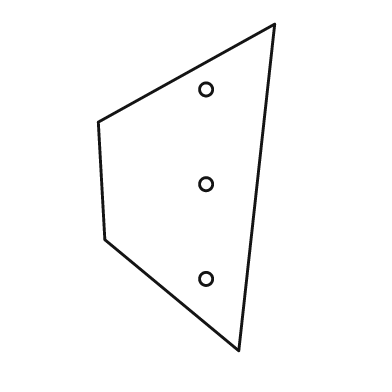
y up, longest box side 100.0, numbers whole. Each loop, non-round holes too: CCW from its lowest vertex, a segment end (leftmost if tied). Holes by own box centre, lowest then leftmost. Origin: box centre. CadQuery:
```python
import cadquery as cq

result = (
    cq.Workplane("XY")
    .moveTo(16.0, -50.0)
    .lineTo(27.0, 50.0)
    .lineTo(-27.0, 20.0)
    .lineTo(-25.0, -16.0)
    .close()
    .moveTo(6.0, -28.0)
    .circle(2.0)
    .moveTo(6.0, 1.0)
    .circle(2.0)
    .moveTo(6.0, 30.0)
    .circle(2.0)
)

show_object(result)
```